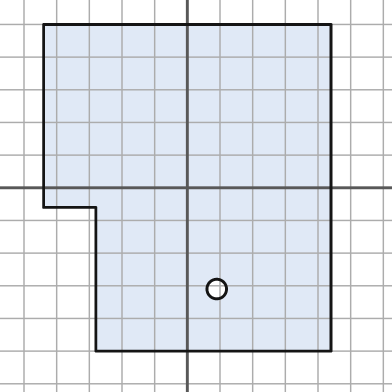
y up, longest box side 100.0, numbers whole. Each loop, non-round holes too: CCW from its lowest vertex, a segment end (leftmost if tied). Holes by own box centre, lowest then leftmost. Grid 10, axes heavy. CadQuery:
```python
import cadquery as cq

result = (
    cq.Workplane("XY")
    .moveTo(-28.0, -50.0)
    .lineTo(44.0, -50.0)
    .lineTo(44.0, 50.0)
    .lineTo(-44.0, 50.0)
    .lineTo(-44.0, -6.0)
    .lineTo(-28.0, -6.0)
    .close()
    .moveTo(9.0, -31.0)
    .circle(3.0)
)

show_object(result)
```